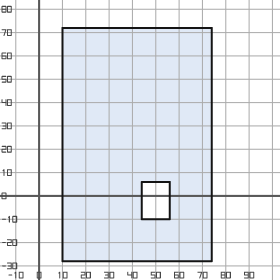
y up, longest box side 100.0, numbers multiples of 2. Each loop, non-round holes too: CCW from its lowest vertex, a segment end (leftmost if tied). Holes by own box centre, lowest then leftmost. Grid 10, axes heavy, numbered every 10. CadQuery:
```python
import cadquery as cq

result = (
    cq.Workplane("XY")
    .moveTo(10.0, -28.0)
    .lineTo(74.0, -28.0)
    .lineTo(74.0, 72.0)
    .lineTo(10.0, 72.0)
    .close()
    .moveTo(44.0, -10.0)
    .lineTo(56.0, -10.0)
    .lineTo(56.0, 6.0)
    .lineTo(44.0, 6.0)
    .close()
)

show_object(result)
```